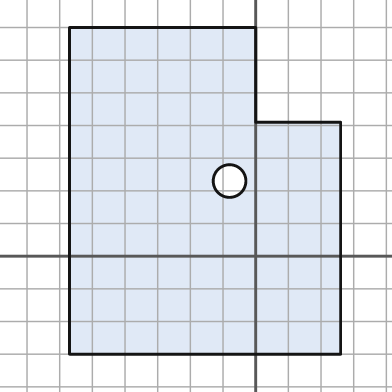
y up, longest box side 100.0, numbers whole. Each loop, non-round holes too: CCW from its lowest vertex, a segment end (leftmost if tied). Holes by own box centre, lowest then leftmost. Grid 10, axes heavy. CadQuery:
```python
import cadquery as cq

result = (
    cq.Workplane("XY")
    .moveTo(-57.0, -30.0)
    .lineTo(26.0, -30.0)
    .lineTo(26.0, 41.0)
    .lineTo(0.0, 41.0)
    .lineTo(0.0, 70.0)
    .lineTo(-57.0, 70.0)
    .close()
    .moveTo(-8.0, 23.0)
    .circle(5.0)
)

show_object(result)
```